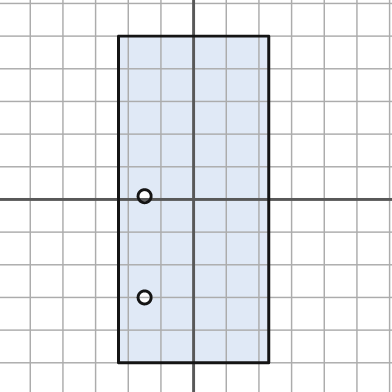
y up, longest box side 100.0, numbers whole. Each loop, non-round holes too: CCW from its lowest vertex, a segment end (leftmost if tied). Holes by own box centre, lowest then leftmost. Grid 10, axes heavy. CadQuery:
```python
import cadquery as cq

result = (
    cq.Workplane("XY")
    .moveTo(-23.0, -50.0)
    .lineTo(23.0, -50.0)
    .lineTo(23.0, 50.0)
    .lineTo(-23.0, 50.0)
    .close()
    .moveTo(-15.0, -30.0)
    .circle(2.0)
    .moveTo(-15.0, 1.0)
    .circle(2.0)
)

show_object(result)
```